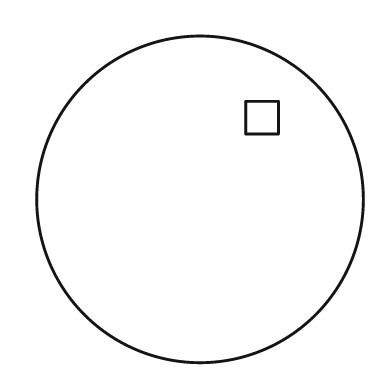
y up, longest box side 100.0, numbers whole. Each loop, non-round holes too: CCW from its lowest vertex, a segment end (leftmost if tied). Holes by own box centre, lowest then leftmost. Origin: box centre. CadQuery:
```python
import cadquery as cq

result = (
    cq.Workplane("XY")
    .moveTo(0.0, 0.0)
    .circle(50.0)
    .moveTo(14.0, 20.0)
    .lineTo(24.0, 20.0)
    .lineTo(24.0, 30.0)
    .lineTo(14.0, 30.0)
    .close()
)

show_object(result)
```